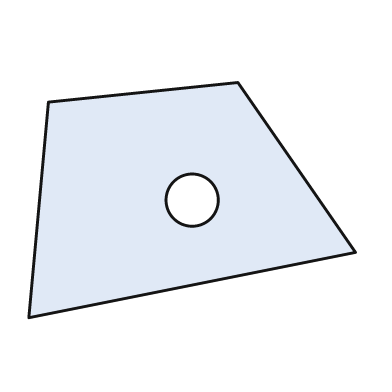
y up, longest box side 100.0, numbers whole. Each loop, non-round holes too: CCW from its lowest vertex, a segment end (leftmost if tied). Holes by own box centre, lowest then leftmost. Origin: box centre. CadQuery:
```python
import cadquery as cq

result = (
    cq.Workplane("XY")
    .moveTo(-50.0, -36.0)
    .lineTo(50.0, -16.0)
    .lineTo(14.0, 36.0)
    .lineTo(-44.0, 30.0)
    .close()
    .moveTo(0.0, 0.0)
    .circle(8.0)
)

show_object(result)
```